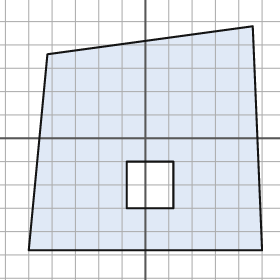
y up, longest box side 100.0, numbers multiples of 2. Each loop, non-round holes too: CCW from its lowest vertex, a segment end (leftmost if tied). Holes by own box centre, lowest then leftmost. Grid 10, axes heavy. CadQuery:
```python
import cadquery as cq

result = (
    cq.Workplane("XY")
    .moveTo(-50.0, -48.0)
    .lineTo(50.0, -48.0)
    .lineTo(46.0, 48.0)
    .lineTo(-42.0, 36.0)
    .close()
    .moveTo(-8.0, -30.0)
    .lineTo(12.0, -30.0)
    .lineTo(12.0, -10.0)
    .lineTo(-8.0, -10.0)
    .close()
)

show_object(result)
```